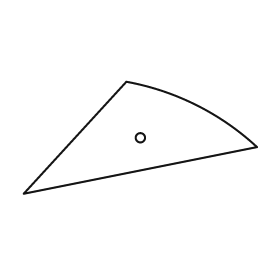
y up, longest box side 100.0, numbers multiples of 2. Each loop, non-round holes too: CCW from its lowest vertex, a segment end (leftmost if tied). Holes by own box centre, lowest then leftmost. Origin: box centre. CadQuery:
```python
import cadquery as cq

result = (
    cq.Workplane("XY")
    .moveTo(-50.0, -24.0)
    .lineTo(50.0, -4.0)
    .threePointArc((24.0, 14.0), (-6.0, 24.0))
    .close()
    .moveTo(0.0, 0.0)
    .circle(2.0)
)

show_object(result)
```